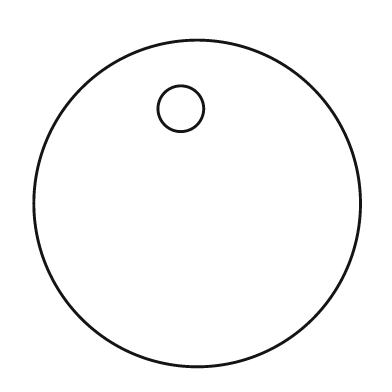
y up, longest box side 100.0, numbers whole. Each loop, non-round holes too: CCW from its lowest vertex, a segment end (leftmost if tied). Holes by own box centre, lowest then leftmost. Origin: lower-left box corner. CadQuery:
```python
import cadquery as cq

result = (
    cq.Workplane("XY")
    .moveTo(50.0, 50.0)
    .circle(50.0)
    .moveTo(45.0, 79.0)
    .circle(7.0)
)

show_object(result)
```